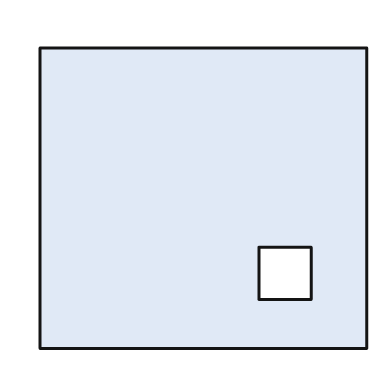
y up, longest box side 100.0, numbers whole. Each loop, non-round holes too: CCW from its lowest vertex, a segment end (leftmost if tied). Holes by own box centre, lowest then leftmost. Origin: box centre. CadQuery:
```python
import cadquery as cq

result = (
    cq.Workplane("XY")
    .moveTo(-50.0, -46.0)
    .lineTo(50.0, -46.0)
    .lineTo(50.0, 46.0)
    .lineTo(-50.0, 46.0)
    .close()
    .moveTo(17.0, -31.0)
    .lineTo(33.0, -31.0)
    .lineTo(33.0, -15.0)
    .lineTo(17.0, -15.0)
    .close()
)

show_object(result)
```